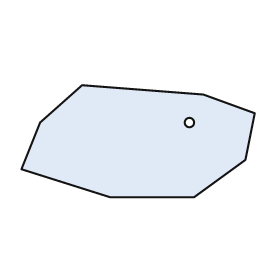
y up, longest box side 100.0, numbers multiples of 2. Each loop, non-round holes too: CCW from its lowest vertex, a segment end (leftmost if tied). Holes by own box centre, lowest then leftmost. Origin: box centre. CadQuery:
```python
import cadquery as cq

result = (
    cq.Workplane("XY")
    .moveTo(-12.0, -24.0)
    .lineTo(24.0, -24.0)
    .lineTo(46.0, -8.0)
    .lineTo(50.0, 12.0)
    .lineTo(28.0, 20.0)
    .lineTo(-24.0, 24.0)
    .lineTo(-42.0, 8.0)
    .lineTo(-50.0, -12.0)
    .close()
    .moveTo(22.0, 8.0)
    .circle(2.0)
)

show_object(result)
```